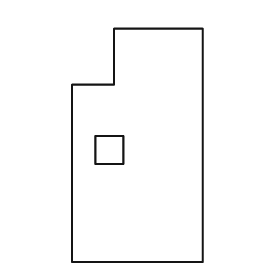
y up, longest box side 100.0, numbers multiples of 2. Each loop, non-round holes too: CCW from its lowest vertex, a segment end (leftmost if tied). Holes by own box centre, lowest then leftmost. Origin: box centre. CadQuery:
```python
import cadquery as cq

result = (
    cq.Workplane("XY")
    .moveTo(-28.0, -50.0)
    .lineTo(28.0, -50.0)
    .lineTo(28.0, 50.0)
    .lineTo(-10.0, 50.0)
    .lineTo(-10.0, 26.0)
    .lineTo(-28.0, 26.0)
    .close()
    .moveTo(-18.0, -8.0)
    .lineTo(-6.0, -8.0)
    .lineTo(-6.0, 4.0)
    .lineTo(-18.0, 4.0)
    .close()
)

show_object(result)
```